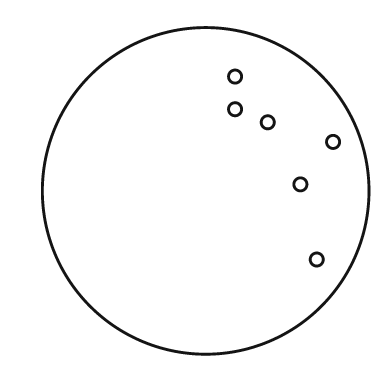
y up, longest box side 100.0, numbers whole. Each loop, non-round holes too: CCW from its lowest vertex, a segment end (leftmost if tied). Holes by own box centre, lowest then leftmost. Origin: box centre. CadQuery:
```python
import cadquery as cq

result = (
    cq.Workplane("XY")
    .moveTo(0.0, 0.0)
    .circle(50.0)
    .moveTo(34.0, -21.0)
    .circle(2.0)
    .moveTo(29.0, 2.0)
    .circle(2.0)
    .moveTo(39.0, 15.0)
    .circle(2.0)
    .moveTo(19.0, 21.0)
    .circle(2.0)
    .moveTo(9.0, 25.0)
    .circle(2.0)
    .moveTo(9.0, 35.0)
    .circle(2.0)
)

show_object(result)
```